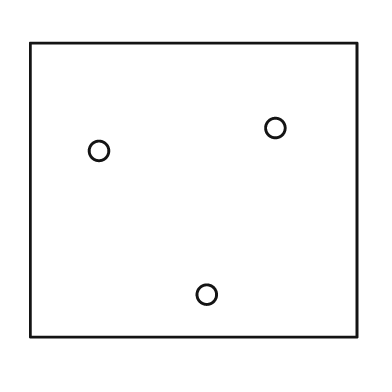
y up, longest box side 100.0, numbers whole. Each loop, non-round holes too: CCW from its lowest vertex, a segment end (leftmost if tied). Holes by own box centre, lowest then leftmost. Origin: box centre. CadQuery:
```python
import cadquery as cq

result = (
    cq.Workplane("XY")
    .moveTo(-50.0, -45.0)
    .lineTo(50.0, -45.0)
    .lineTo(50.0, 45.0)
    .lineTo(-50.0, 45.0)
    .close()
    .moveTo(4.0, -32.0)
    .circle(3.0)
    .moveTo(-29.0, 12.0)
    .circle(3.0)
    .moveTo(25.0, 19.0)
    .circle(3.0)
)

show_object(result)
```